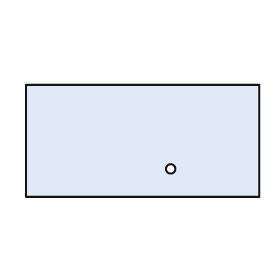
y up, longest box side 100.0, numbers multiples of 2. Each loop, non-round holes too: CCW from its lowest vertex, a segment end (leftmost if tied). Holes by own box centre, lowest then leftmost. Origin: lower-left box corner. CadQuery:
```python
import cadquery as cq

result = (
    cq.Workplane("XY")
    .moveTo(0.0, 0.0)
    .lineTo(100.0, 0.0)
    .lineTo(100.0, 48.0)
    .lineTo(0.0, 48.0)
    .close()
    .moveTo(62.0, 12.0)
    .circle(2.0)
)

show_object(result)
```